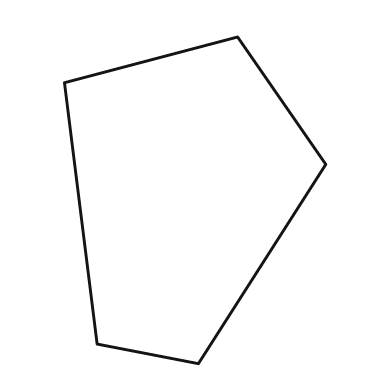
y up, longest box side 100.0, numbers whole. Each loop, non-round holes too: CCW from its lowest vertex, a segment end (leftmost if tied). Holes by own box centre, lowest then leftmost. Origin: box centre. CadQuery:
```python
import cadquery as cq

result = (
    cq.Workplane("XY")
    .moveTo(1.0, -50.0)
    .lineTo(40.0, 11.0)
    .lineTo(13.0, 50.0)
    .lineTo(-40.0, 36.0)
    .lineTo(-30.0, -44.0)
    .close()
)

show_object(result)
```